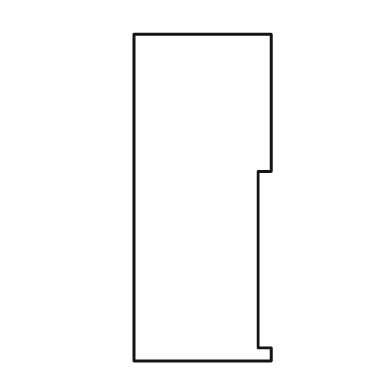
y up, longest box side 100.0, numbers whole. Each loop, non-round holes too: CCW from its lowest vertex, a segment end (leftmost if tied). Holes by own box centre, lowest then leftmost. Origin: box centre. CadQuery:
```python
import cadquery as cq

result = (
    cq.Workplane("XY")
    .moveTo(-21.0, -50.0)
    .lineTo(21.0, -50.0)
    .lineTo(21.0, -46.0)
    .lineTo(17.0, -46.0)
    .lineTo(17.0, 8.0)
    .lineTo(21.0, 8.0)
    .lineTo(21.0, 50.0)
    .lineTo(-21.0, 50.0)
    .close()
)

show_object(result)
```